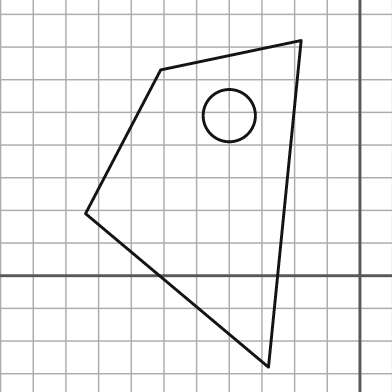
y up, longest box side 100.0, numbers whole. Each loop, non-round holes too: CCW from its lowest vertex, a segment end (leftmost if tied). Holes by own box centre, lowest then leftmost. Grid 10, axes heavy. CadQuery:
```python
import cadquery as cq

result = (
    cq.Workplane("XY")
    .moveTo(-28.0, -28.0)
    .lineTo(-18.0, 72.0)
    .lineTo(-61.0, 63.0)
    .lineTo(-84.0, 19.0)
    .close()
    .moveTo(-40.0, 49.0)
    .circle(8.0)
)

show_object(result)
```